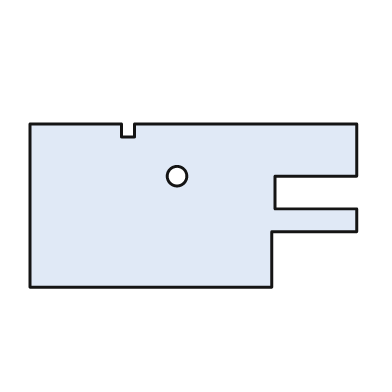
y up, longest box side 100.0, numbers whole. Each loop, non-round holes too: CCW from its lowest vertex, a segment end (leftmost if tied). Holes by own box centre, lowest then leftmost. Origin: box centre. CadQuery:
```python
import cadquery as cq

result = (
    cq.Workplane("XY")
    .moveTo(-50.0, -25.0)
    .lineTo(24.0, -25.0)
    .lineTo(24.0, -8.0)
    .lineTo(50.0, -8.0)
    .lineTo(50.0, -1.0)
    .lineTo(25.0, -1.0)
    .lineTo(25.0, 9.0)
    .lineTo(50.0, 9.0)
    .lineTo(50.0, 25.0)
    .lineTo(-18.0, 25.0)
    .lineTo(-18.0, 21.0)
    .lineTo(-22.0, 21.0)
    .lineTo(-22.0, 25.0)
    .lineTo(-50.0, 25.0)
    .close()
    .moveTo(-5.0, 9.0)
    .circle(3.0)
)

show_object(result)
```